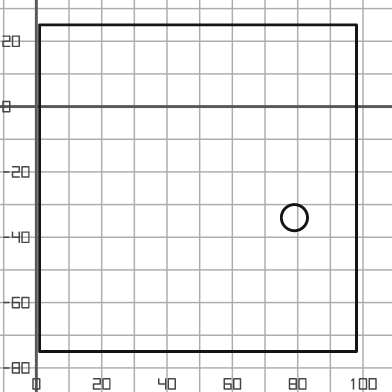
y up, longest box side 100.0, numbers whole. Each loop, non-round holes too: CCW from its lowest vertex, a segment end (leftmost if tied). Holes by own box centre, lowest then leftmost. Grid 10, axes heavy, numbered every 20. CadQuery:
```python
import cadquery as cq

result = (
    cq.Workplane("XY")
    .moveTo(1.0, -75.0)
    .lineTo(98.0, -75.0)
    .lineTo(98.0, 25.0)
    .lineTo(1.0, 25.0)
    .close()
    .moveTo(79.0, -34.0)
    .circle(4.0)
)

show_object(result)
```